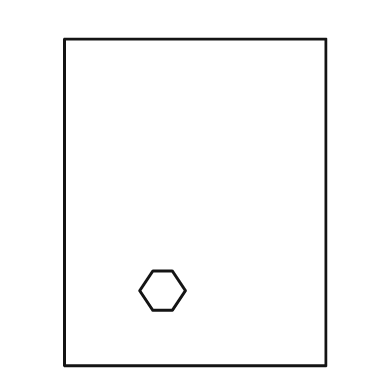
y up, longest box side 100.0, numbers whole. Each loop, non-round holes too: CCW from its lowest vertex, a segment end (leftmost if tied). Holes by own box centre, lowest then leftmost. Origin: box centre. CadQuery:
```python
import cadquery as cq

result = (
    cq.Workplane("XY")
    .moveTo(-40.0, -50.0)
    .lineTo(40.0, -50.0)
    .lineTo(40.0, 50.0)
    .lineTo(-40.0, 50.0)
    .close()
    .moveTo(-13.0, -33.0)
    .lineTo(-7.0, -33.0)
    .lineTo(-3.0, -27.0)
    .lineTo(-7.0, -21.0)
    .lineTo(-13.0, -21.0)
    .lineTo(-17.0, -27.0)
    .close()
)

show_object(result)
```